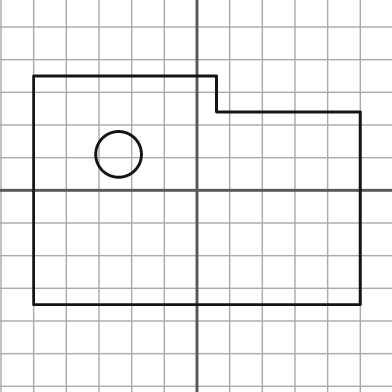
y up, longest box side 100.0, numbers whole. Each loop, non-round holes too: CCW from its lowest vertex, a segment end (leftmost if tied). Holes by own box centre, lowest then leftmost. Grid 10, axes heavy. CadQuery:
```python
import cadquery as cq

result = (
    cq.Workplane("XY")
    .moveTo(-50.0, -35.0)
    .lineTo(50.0, -35.0)
    .lineTo(50.0, 24.0)
    .lineTo(6.0, 24.0)
    .lineTo(6.0, 35.0)
    .lineTo(-50.0, 35.0)
    .close()
    .moveTo(-24.0, 11.0)
    .circle(7.0)
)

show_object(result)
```